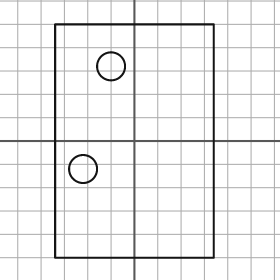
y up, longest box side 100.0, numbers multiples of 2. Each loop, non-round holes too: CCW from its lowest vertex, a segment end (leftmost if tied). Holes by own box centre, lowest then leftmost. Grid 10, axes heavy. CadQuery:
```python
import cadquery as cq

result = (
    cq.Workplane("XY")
    .moveTo(-34.0, -50.0)
    .lineTo(34.0, -50.0)
    .lineTo(34.0, 50.0)
    .lineTo(-34.0, 50.0)
    .close()
    .moveTo(-22.0, -12.0)
    .circle(6.0)
    .moveTo(-10.0, 32.0)
    .circle(6.0)
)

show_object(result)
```